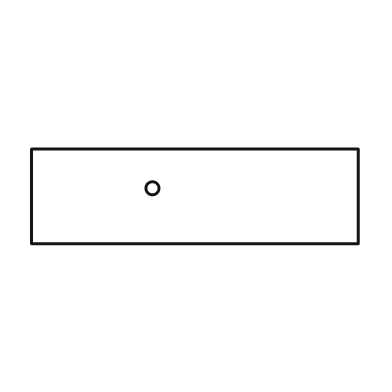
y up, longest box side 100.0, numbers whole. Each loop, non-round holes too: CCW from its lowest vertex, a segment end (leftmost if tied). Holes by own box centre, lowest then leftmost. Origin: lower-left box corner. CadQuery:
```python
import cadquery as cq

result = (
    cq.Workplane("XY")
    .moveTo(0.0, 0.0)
    .lineTo(100.0, 0.0)
    .lineTo(100.0, 29.0)
    .lineTo(0.0, 29.0)
    .close()
    .moveTo(37.0, 17.0)
    .circle(2.0)
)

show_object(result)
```